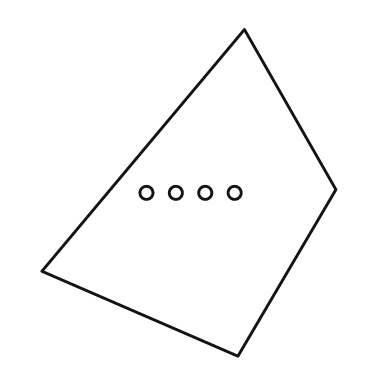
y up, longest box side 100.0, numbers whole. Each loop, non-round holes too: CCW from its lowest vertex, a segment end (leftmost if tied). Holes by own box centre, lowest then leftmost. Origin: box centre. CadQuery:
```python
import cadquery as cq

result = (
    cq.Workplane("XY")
    .moveTo(15.0, -50.0)
    .lineTo(45.0, 1.0)
    .lineTo(17.0, 50.0)
    .lineTo(-45.0, -24.0)
    .close()
    .moveTo(-13.0, 0.0)
    .circle(2.0)
    .moveTo(-4.0, 0.0)
    .circle(2.0)
    .moveTo(5.0, 0.0)
    .circle(2.0)
    .moveTo(14.0, 0.0)
    .circle(2.0)
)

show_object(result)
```